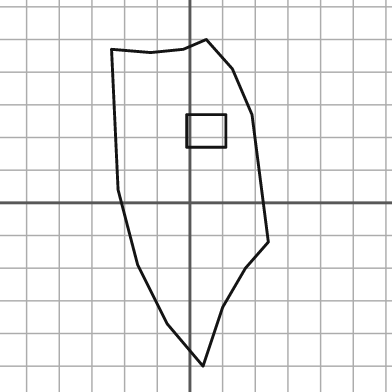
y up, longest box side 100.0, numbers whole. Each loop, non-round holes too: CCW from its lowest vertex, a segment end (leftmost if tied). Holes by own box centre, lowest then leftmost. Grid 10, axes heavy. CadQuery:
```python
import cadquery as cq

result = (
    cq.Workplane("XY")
    .moveTo(4.0, -50.0)
    .lineTo(10.0, -32.0)
    .lineTo(17.0, -20.0)
    .lineTo(24.0, -12.0)
    .lineTo(19.0, 27.0)
    .lineTo(13.0, 41.0)
    .lineTo(5.0, 50.0)
    .lineTo(-2.0, 47.0)
    .lineTo(-12.0, 46.0)
    .lineTo(-24.0, 47.0)
    .lineTo(-22.0, 4.0)
    .lineTo(-16.0, -19.0)
    .lineTo(-7.0, -37.0)
    .close()
    .moveTo(-1.0, 17.0)
    .lineTo(11.0, 17.0)
    .lineTo(11.0, 27.0)
    .lineTo(-1.0, 27.0)
    .close()
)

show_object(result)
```